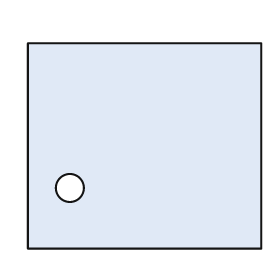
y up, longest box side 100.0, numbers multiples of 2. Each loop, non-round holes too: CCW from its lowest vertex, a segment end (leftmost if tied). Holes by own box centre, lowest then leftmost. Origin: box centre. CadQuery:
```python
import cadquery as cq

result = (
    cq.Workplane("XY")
    .moveTo(-50.0, -44.0)
    .lineTo(50.0, -44.0)
    .lineTo(50.0, 44.0)
    .lineTo(-50.0, 44.0)
    .close()
    .moveTo(-32.0, -18.0)
    .circle(6.0)
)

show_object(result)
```